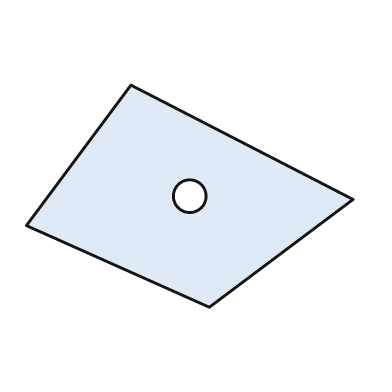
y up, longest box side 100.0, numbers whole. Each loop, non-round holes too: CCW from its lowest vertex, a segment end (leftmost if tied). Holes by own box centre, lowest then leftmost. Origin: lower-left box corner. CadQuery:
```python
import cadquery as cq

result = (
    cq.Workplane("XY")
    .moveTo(56.0, 0.0)
    .lineTo(100.0, 33.0)
    .lineTo(32.0, 68.0)
    .lineTo(0.0, 25.0)
    .close()
    .moveTo(50.0, 34.0)
    .circle(5.0)
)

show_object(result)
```